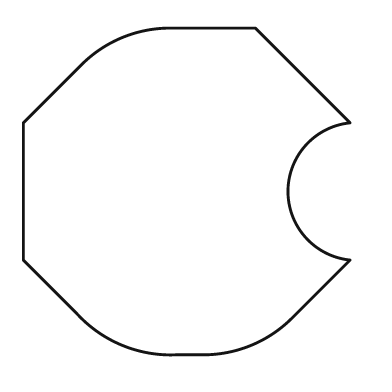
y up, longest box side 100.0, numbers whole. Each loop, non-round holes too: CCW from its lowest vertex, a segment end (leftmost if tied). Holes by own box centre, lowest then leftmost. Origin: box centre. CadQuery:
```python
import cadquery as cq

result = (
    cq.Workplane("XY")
    .moveTo(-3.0, -50.0)
    .lineTo(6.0, -50.0)
    .threePointArc((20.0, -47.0), (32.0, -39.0))
    .lineTo(50.0, -21.0)
    .threePointArc((31.0, 0.0), (50.0, 21.0))
    .lineTo(21.0, 50.0)
    .lineTo(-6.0, 50.0)
    .threePointArc((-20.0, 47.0), (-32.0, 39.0))
    .lineTo(-50.0, 21.0)
    .lineTo(-50.0, -21.0)
    .lineTo(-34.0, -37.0)
    .threePointArc((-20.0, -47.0), (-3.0, -50.0))
    .close()
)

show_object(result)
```